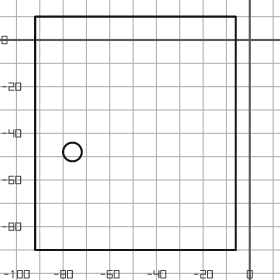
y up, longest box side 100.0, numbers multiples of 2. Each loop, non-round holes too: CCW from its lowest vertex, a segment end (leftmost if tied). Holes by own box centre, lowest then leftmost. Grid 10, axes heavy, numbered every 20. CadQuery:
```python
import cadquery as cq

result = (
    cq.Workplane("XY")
    .moveTo(-92.0, -90.0)
    .lineTo(-6.0, -90.0)
    .lineTo(-6.0, 10.0)
    .lineTo(-92.0, 10.0)
    .close()
    .moveTo(-76.0, -48.0)
    .circle(4.0)
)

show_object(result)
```